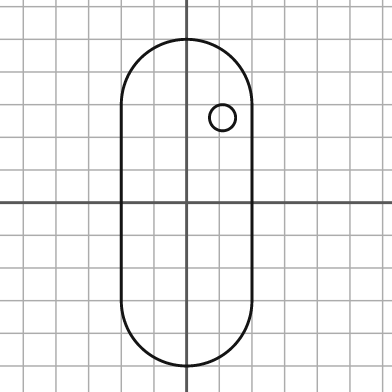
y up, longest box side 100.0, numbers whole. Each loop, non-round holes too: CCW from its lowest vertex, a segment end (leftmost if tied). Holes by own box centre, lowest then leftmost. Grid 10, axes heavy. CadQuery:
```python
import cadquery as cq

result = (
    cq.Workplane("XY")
    .moveTo(-20.0, -30.0)
    .threePointArc((0.0, -50.0), (20.0, -30.0))
    .lineTo(20.0, 30.0)
    .threePointArc((0.0, 50.0), (-20.0, 30.0))
    .close()
    .moveTo(11.0, 26.0)
    .circle(4.0)
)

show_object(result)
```